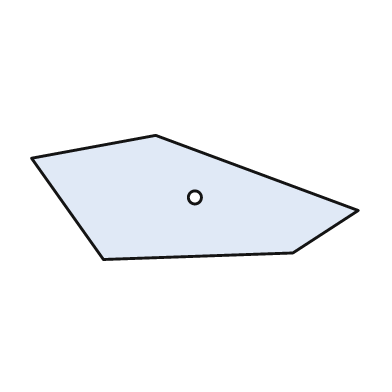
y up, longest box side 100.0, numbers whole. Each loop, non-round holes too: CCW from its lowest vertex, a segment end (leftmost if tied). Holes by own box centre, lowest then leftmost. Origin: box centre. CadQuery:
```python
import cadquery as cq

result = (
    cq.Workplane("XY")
    .moveTo(-28.0, -19.0)
    .lineTo(30.0, -17.0)
    .lineTo(50.0, -4.0)
    .lineTo(-12.0, 19.0)
    .lineTo(-50.0, 12.0)
    .close()
    .moveTo(0.0, 0.0)
    .circle(2.0)
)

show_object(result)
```